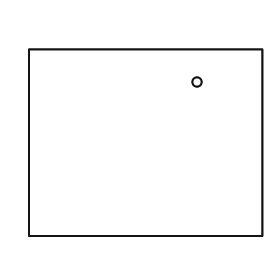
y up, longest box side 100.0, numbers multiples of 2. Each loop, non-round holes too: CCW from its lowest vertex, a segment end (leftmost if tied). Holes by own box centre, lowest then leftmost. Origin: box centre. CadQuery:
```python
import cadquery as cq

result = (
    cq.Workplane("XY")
    .moveTo(-50.0, -40.0)
    .lineTo(50.0, -40.0)
    .lineTo(50.0, 40.0)
    .lineTo(-50.0, 40.0)
    .close()
    .moveTo(22.0, 26.0)
    .circle(2.0)
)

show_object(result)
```